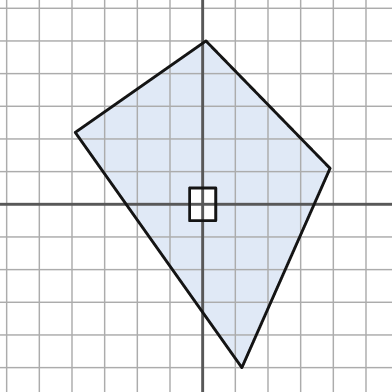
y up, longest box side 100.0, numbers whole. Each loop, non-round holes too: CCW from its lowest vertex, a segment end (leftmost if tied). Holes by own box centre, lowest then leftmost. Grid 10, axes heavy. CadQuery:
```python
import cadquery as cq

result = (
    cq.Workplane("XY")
    .moveTo(12.0, -50.0)
    .lineTo(39.0, 11.0)
    .lineTo(1.0, 50.0)
    .lineTo(-39.0, 22.0)
    .close()
    .moveTo(-4.0, -5.0)
    .lineTo(4.0, -5.0)
    .lineTo(4.0, 5.0)
    .lineTo(-4.0, 5.0)
    .close()
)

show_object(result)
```